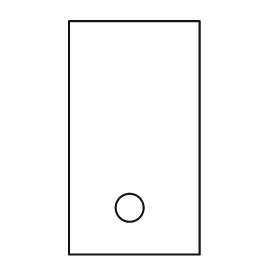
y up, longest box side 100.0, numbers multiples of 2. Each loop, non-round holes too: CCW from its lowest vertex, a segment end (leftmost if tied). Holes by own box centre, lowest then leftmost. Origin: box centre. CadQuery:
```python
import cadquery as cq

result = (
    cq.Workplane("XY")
    .moveTo(-28.0, -50.0)
    .lineTo(28.0, -50.0)
    .lineTo(28.0, 50.0)
    .lineTo(-28.0, 50.0)
    .close()
    .moveTo(-2.0, -30.0)
    .circle(6.0)
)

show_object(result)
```